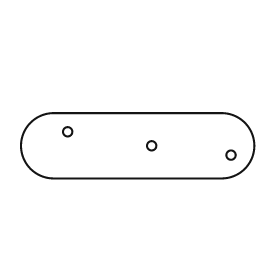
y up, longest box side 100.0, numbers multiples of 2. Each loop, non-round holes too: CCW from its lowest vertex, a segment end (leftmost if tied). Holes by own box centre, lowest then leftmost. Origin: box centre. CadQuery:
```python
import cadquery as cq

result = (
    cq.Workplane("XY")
    .moveTo(-36.0, -14.0)
    .lineTo(36.0, -14.0)
    .threePointArc((50.0, 0.0), (36.0, 14.0))
    .lineTo(-36.0, 14.0)
    .threePointArc((-50.0, 0.0), (-36.0, -14.0))
    .close()
    .moveTo(40.0, -4.0)
    .circle(2.0)
    .moveTo(6.0, 0.0)
    .circle(2.0)
    .moveTo(-30.0, 6.0)
    .circle(2.0)
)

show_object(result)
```